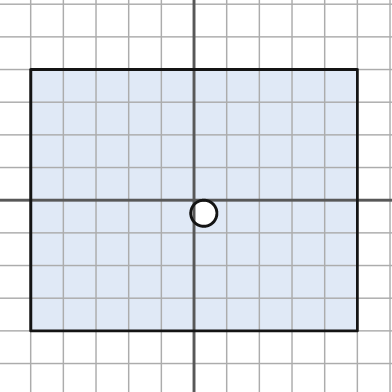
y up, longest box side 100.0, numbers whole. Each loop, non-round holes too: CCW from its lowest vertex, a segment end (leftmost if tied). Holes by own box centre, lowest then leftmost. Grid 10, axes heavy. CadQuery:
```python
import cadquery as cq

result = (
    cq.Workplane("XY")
    .moveTo(-50.0, -40.0)
    .lineTo(50.0, -40.0)
    .lineTo(50.0, 40.0)
    .lineTo(-50.0, 40.0)
    .close()
    .moveTo(3.0, -4.0)
    .circle(4.0)
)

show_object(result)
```